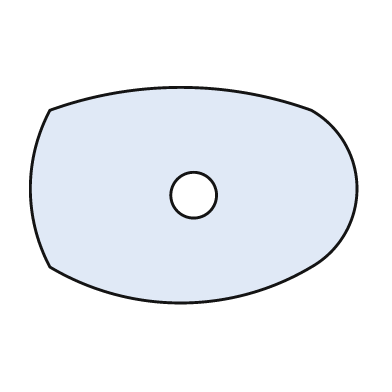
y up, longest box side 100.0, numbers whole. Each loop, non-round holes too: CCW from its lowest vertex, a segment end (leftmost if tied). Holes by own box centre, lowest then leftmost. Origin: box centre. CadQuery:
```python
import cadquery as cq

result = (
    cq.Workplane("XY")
    .moveTo(-44.0, -22.0)
    .threePointArc((-4.0, -33.0), (36.0, -22.0))
    .threePointArc((50.0, 2.0), (36.0, 26.0))
    .threePointArc((-4.0, 33.0), (-44.0, 26.0))
    .threePointArc((-50.0, 2.0), (-44.0, -22.0))
    .close()
    .moveTo(0.0, 0.0)
    .circle(7.0)
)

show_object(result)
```